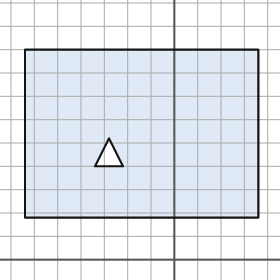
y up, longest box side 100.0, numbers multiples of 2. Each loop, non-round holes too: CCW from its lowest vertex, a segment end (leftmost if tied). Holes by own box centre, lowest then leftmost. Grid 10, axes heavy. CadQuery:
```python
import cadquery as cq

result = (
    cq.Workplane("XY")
    .moveTo(-64.0, 18.0)
    .lineTo(36.0, 18.0)
    .lineTo(36.0, 90.0)
    .lineTo(-64.0, 90.0)
    .close()
    .moveTo(-34.0, 40.0)
    .lineTo(-22.0, 40.0)
    .lineTo(-28.0, 52.0)
    .close()
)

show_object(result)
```